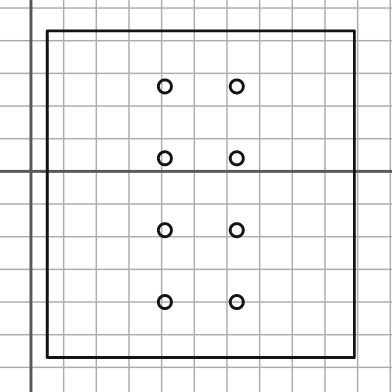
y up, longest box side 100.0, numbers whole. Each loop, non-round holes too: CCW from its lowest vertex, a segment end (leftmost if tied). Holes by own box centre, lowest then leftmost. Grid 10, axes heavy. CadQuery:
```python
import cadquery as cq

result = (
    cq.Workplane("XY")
    .moveTo(5.0, -57.0)
    .lineTo(99.0, -57.0)
    .lineTo(99.0, 43.0)
    .lineTo(5.0, 43.0)
    .close()
    .moveTo(41.0, -40.0)
    .circle(2.0)
    .moveTo(63.0, -40.0)
    .circle(2.0)
    .moveTo(41.0, -18.0)
    .circle(2.0)
    .moveTo(63.0, -18.0)
    .circle(2.0)
    .moveTo(41.0, 4.0)
    .circle(2.0)
    .moveTo(63.0, 4.0)
    .circle(2.0)
    .moveTo(41.0, 26.0)
    .circle(2.0)
    .moveTo(63.0, 26.0)
    .circle(2.0)
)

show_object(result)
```